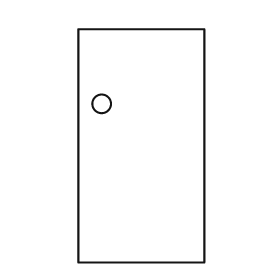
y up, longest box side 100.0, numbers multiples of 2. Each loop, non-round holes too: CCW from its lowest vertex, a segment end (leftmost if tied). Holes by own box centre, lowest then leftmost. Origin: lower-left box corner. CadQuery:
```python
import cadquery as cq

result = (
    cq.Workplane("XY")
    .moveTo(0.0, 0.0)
    .lineTo(54.0, 0.0)
    .lineTo(54.0, 100.0)
    .lineTo(0.0, 100.0)
    .close()
    .moveTo(10.0, 68.0)
    .circle(4.0)
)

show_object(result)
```